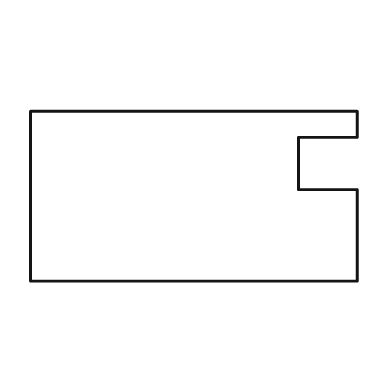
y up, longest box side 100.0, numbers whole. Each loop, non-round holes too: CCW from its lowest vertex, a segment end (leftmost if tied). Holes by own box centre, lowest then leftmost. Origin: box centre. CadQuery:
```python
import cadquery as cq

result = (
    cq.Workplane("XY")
    .moveTo(-50.0, -26.0)
    .lineTo(50.0, -26.0)
    .lineTo(50.0, 2.0)
    .lineTo(32.0, 2.0)
    .lineTo(32.0, 18.0)
    .lineTo(50.0, 18.0)
    .lineTo(50.0, 26.0)
    .lineTo(-50.0, 26.0)
    .close()
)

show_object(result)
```